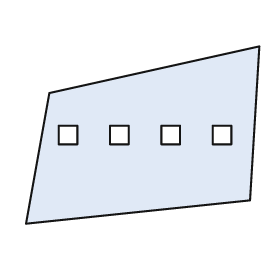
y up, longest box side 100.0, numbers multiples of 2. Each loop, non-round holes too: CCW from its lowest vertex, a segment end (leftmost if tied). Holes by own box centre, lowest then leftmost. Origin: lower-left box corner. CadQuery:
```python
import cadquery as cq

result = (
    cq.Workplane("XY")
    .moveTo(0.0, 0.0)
    .lineTo(96.0, 10.0)
    .lineTo(100.0, 76.0)
    .lineTo(10.0, 56.0)
    .close()
    .moveTo(14.0, 34.0)
    .lineTo(22.0, 34.0)
    .lineTo(22.0, 42.0)
    .lineTo(14.0, 42.0)
    .close()
    .moveTo(36.0, 34.0)
    .lineTo(44.0, 34.0)
    .lineTo(44.0, 42.0)
    .lineTo(36.0, 42.0)
    .close()
    .moveTo(58.0, 34.0)
    .lineTo(66.0, 34.0)
    .lineTo(66.0, 42.0)
    .lineTo(58.0, 42.0)
    .close()
    .moveTo(80.0, 34.0)
    .lineTo(88.0, 34.0)
    .lineTo(88.0, 42.0)
    .lineTo(80.0, 42.0)
    .close()
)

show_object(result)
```